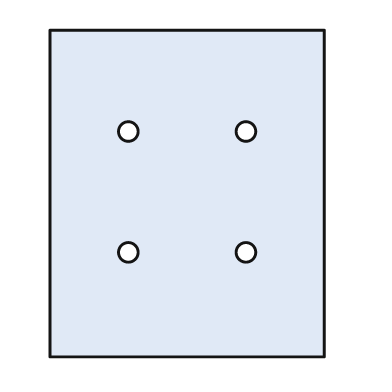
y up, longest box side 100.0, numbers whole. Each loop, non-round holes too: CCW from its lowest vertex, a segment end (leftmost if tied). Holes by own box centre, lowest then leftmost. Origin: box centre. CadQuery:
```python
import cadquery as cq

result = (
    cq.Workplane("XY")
    .moveTo(-42.0, -50.0)
    .lineTo(42.0, -50.0)
    .lineTo(42.0, 50.0)
    .lineTo(-42.0, 50.0)
    .close()
    .moveTo(-18.0, -18.0)
    .circle(3.0)
    .moveTo(18.0, -18.0)
    .circle(3.0)
    .moveTo(-18.0, 19.0)
    .circle(3.0)
    .moveTo(18.0, 19.0)
    .circle(3.0)
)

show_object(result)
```